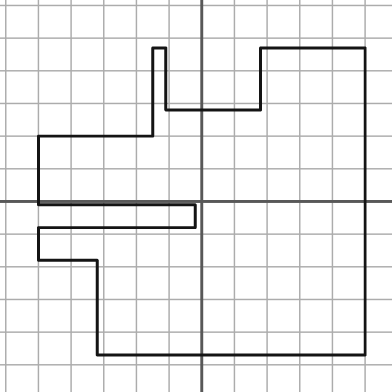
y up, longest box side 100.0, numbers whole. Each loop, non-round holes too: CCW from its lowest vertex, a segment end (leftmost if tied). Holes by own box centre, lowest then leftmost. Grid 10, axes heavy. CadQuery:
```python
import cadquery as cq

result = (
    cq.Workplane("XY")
    .moveTo(-32.0, -47.0)
    .lineTo(50.0, -47.0)
    .lineTo(50.0, 47.0)
    .lineTo(18.0, 47.0)
    .lineTo(18.0, 28.0)
    .lineTo(-11.0, 28.0)
    .lineTo(-11.0, 47.0)
    .lineTo(-15.0, 47.0)
    .lineTo(-15.0, 20.0)
    .lineTo(-50.0, 20.0)
    .lineTo(-50.0, -1.0)
    .lineTo(-2.0, -1.0)
    .lineTo(-2.0, -8.0)
    .lineTo(-50.0, -8.0)
    .lineTo(-50.0, -18.0)
    .lineTo(-32.0, -18.0)
    .close()
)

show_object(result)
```